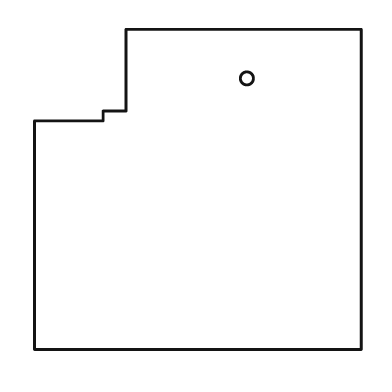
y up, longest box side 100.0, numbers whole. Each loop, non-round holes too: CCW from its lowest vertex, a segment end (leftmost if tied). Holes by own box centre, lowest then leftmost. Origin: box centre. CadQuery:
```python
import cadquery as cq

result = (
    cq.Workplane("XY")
    .moveTo(-50.0, -49.0)
    .lineTo(50.0, -49.0)
    .lineTo(50.0, 49.0)
    .lineTo(-22.0, 49.0)
    .lineTo(-22.0, 24.0)
    .lineTo(-29.0, 24.0)
    .lineTo(-29.0, 21.0)
    .lineTo(-50.0, 21.0)
    .close()
    .moveTo(15.0, 34.0)
    .circle(2.0)
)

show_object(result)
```